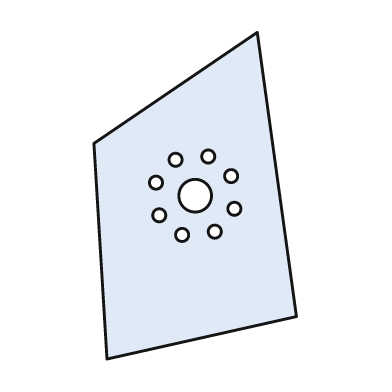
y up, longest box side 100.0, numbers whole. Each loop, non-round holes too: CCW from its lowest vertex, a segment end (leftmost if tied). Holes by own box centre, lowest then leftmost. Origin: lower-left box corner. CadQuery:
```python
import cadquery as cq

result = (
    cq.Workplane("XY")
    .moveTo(4.0, 0.0)
    .lineTo(62.0, 13.0)
    .lineTo(50.0, 100.0)
    .lineTo(0.0, 66.0)
    .close()
    .moveTo(27.0, 38.0)
    .circle(2.0)
    .moveTo(37.0, 39.0)
    .circle(2.0)
    .moveTo(20.0, 44.0)
    .circle(2.0)
    .moveTo(43.0, 46.0)
    .circle(2.0)
    .moveTo(31.0, 50.0)
    .circle(5.0)
    .moveTo(19.0, 54.0)
    .circle(2.0)
    .moveTo(42.0, 56.0)
    .circle(2.0)
    .moveTo(25.0, 61.0)
    .circle(2.0)
    .moveTo(35.0, 62.0)
    .circle(2.0)
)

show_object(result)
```